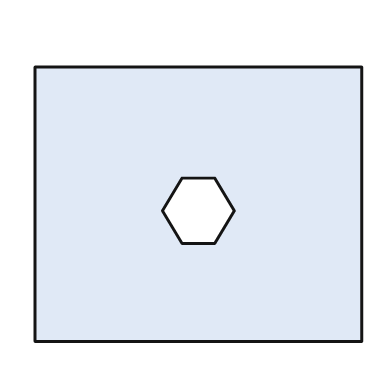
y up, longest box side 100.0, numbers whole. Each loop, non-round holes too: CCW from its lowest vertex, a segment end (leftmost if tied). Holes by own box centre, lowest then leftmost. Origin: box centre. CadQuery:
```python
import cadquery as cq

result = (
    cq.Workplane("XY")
    .moveTo(-50.0, -42.0)
    .lineTo(50.0, -42.0)
    .lineTo(50.0, 42.0)
    .lineTo(-50.0, 42.0)
    .close()
    .moveTo(-5.0, -12.0)
    .lineTo(5.0, -12.0)
    .lineTo(11.0, -2.0)
    .lineTo(5.0, 8.0)
    .lineTo(-5.0, 8.0)
    .lineTo(-11.0, -2.0)
    .close()
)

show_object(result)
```